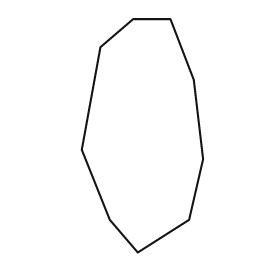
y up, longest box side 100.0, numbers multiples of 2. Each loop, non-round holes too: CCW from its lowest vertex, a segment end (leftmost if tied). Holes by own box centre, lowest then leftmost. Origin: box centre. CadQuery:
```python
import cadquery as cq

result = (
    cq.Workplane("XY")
    .moveTo(-2.0, -50.0)
    .lineTo(20.0, -36.0)
    .lineTo(26.0, -10.0)
    .lineTo(22.0, 24.0)
    .lineTo(12.0, 50.0)
    .lineTo(-4.0, 50.0)
    .lineTo(-18.0, 38.0)
    .lineTo(-26.0, -6.0)
    .lineTo(-14.0, -36.0)
    .close()
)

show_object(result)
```